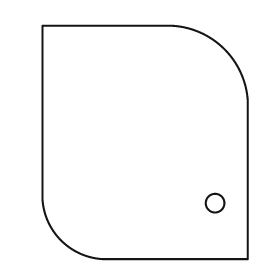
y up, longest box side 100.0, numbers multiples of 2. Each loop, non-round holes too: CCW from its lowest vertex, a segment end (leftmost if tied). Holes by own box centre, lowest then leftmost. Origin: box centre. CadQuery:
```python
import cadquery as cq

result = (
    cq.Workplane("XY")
    .moveTo(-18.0, -50.0)
    .lineTo(44.0, -50.0)
    .lineTo(44.0, 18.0)
    .threePointArc((34.0, 40.0), (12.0, 50.0))
    .lineTo(-44.0, 50.0)
    .lineTo(-44.0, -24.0)
    .threePointArc((-36.0, -42.0), (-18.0, -50.0))
    .close()
    .moveTo(30.0, -26.0)
    .circle(4.0)
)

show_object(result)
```